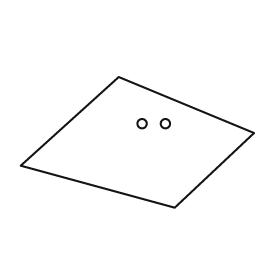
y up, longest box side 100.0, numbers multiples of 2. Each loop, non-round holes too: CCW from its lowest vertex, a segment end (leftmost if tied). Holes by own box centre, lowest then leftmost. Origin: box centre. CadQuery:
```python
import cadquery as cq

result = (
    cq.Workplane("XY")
    .moveTo(16.0, -28.0)
    .lineTo(50.0, 4.0)
    .lineTo(-8.0, 28.0)
    .lineTo(-50.0, -10.0)
    .close()
    .moveTo(2.0, 8.0)
    .circle(2.0)
    .moveTo(12.0, 8.0)
    .circle(2.0)
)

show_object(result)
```